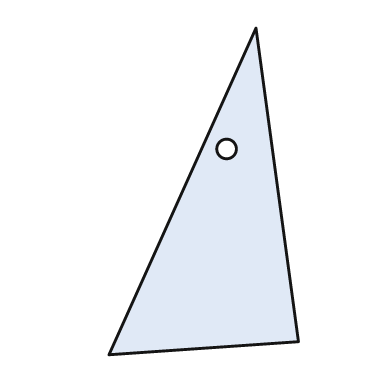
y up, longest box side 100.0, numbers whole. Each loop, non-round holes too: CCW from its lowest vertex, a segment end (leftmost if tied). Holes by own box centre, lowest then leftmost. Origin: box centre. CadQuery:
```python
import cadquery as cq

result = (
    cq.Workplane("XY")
    .moveTo(-29.0, -50.0)
    .lineTo(29.0, -46.0)
    .lineTo(16.0, 50.0)
    .close()
    .moveTo(7.0, 13.0)
    .circle(3.0)
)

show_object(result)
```